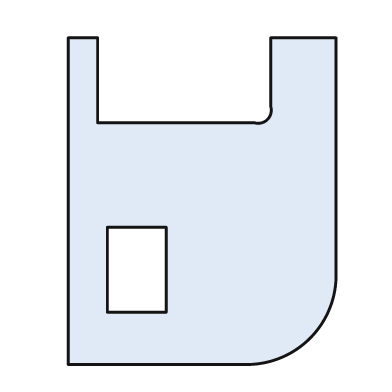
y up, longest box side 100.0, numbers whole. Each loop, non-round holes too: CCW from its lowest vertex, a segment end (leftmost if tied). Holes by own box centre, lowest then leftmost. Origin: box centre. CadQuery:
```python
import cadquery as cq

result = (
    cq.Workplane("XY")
    .moveTo(-41.0, -50.0)
    .lineTo(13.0, -50.0)
    .threePointArc((33.0, -42.0), (41.0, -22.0))
    .lineTo(41.0, 50.0)
    .lineTo(21.0, 50.0)
    .lineTo(21.0, 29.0)
    .threePointArc((20.0, 25.0), (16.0, 24.0))
    .lineTo(-32.0, 24.0)
    .lineTo(-32.0, 50.0)
    .lineTo(-41.0, 50.0)
    .close()
    .moveTo(-29.0, -34.0)
    .lineTo(-11.0, -34.0)
    .lineTo(-11.0, -8.0)
    .lineTo(-29.0, -8.0)
    .close()
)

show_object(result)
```